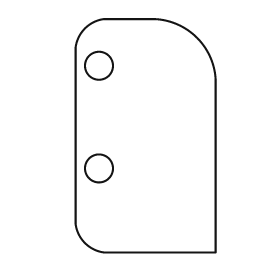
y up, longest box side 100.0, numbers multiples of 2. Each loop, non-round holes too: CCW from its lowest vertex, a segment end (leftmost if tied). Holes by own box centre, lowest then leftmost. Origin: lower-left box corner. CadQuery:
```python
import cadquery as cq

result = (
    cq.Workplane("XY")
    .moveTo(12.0, 0.0)
    .lineTo(60.0, 0.0)
    .lineTo(60.0, 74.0)
    .threePointArc((52.0, 92.0), (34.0, 100.0))
    .lineTo(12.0, 100.0)
    .threePointArc((4.0, 96.0), (0.0, 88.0))
    .lineTo(0.0, 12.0)
    .threePointArc((4.0, 4.0), (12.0, 0.0))
    .close()
    .moveTo(10.0, 36.0)
    .circle(6.0)
    .moveTo(10.0, 80.0)
    .circle(6.0)
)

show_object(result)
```